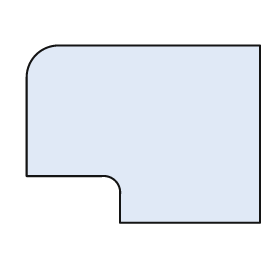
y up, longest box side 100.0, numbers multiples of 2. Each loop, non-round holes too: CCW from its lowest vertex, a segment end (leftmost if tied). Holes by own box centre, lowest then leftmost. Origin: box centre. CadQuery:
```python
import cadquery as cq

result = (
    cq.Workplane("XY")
    .moveTo(-10.0, -38.0)
    .lineTo(50.0, -38.0)
    .lineTo(50.0, 38.0)
    .lineTo(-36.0, 38.0)
    .threePointArc((-46.0, 34.0), (-50.0, 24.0))
    .lineTo(-50.0, -18.0)
    .lineTo(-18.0, -18.0)
    .threePointArc((-12.0, -20.0), (-10.0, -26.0))
    .close()
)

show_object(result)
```